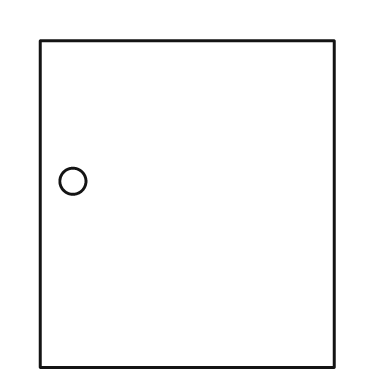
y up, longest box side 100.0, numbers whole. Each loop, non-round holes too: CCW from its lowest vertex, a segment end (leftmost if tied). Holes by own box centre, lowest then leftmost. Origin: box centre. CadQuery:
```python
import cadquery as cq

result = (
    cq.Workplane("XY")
    .moveTo(-45.0, -50.0)
    .lineTo(45.0, -50.0)
    .lineTo(45.0, 50.0)
    .lineTo(-45.0, 50.0)
    .close()
    .moveTo(-35.0, 7.0)
    .circle(4.0)
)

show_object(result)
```